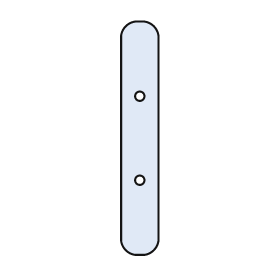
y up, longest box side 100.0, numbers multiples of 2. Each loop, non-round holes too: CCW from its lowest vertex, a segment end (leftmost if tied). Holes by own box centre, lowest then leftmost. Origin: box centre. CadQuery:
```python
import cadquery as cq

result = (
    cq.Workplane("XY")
    .moveTo(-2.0, -50.0)
    .lineTo(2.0, -50.0)
    .threePointArc((6.0, -48.0), (8.0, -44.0))
    .lineTo(8.0, 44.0)
    .threePointArc((6.0, 48.0), (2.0, 50.0))
    .lineTo(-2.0, 50.0)
    .threePointArc((-6.0, 48.0), (-8.0, 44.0))
    .lineTo(-8.0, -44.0)
    .threePointArc((-6.0, -48.0), (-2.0, -50.0))
    .close()
    .moveTo(0.0, -18.0)
    .circle(2.0)
    .moveTo(0.0, 18.0)
    .circle(2.0)
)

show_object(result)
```